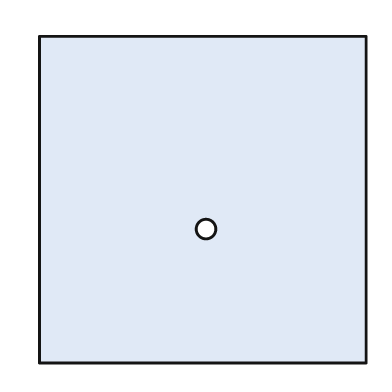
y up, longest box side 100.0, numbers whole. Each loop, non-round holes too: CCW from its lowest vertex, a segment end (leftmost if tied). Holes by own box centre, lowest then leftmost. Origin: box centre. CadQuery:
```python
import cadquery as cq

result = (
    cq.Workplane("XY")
    .moveTo(-50.0, -50.0)
    .lineTo(50.0, -50.0)
    .lineTo(50.0, 50.0)
    .lineTo(-50.0, 50.0)
    .close()
    .moveTo(1.0, -9.0)
    .circle(3.0)
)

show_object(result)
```